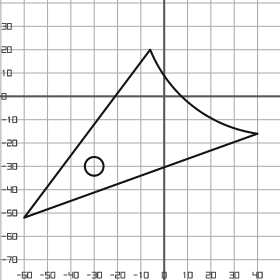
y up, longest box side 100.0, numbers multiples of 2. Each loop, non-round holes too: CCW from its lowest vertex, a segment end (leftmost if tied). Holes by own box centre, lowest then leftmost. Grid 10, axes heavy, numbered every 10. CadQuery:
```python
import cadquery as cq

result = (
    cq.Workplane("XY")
    .moveTo(-60.0, -52.0)
    .lineTo(40.0, -16.0)
    .threePointArc((12.0, -4.0), (-6.0, 20.0))
    .close()
    .moveTo(-30.0, -30.0)
    .circle(4.0)
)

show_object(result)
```